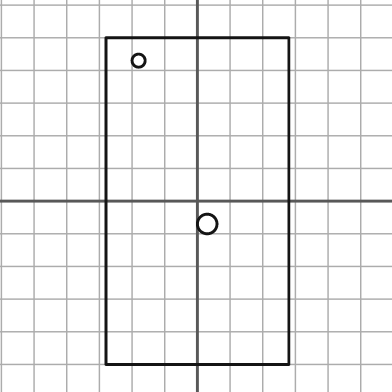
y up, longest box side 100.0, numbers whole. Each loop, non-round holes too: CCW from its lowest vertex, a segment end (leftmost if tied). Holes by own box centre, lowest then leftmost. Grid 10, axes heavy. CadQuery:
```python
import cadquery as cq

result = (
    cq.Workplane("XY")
    .moveTo(-28.0, -50.0)
    .lineTo(28.0, -50.0)
    .lineTo(28.0, 50.0)
    .lineTo(-28.0, 50.0)
    .close()
    .moveTo(3.0, -7.0)
    .circle(3.0)
    .moveTo(-18.0, 43.0)
    .circle(2.0)
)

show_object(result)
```